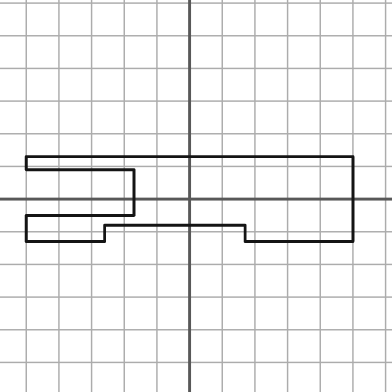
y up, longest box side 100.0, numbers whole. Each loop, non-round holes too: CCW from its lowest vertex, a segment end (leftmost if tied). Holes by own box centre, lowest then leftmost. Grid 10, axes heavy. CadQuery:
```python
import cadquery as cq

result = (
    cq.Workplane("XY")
    .moveTo(-50.0, -13.0)
    .lineTo(-26.0, -13.0)
    .lineTo(-26.0, -8.0)
    .lineTo(17.0, -8.0)
    .lineTo(17.0, -13.0)
    .lineTo(50.0, -13.0)
    .lineTo(50.0, 13.0)
    .lineTo(-50.0, 13.0)
    .lineTo(-50.0, 9.0)
    .lineTo(-17.0, 9.0)
    .lineTo(-17.0, -5.0)
    .lineTo(-50.0, -5.0)
    .close()
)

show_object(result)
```